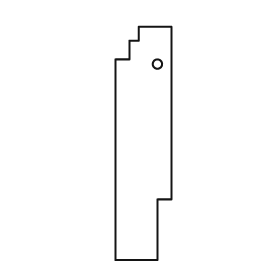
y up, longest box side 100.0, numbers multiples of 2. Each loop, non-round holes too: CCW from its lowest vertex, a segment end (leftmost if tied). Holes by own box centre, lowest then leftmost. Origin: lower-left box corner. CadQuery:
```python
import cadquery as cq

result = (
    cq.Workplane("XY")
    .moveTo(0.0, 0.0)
    .lineTo(18.0, 0.0)
    .lineTo(18.0, 26.0)
    .lineTo(24.0, 26.0)
    .lineTo(24.0, 100.0)
    .lineTo(10.0, 100.0)
    .lineTo(10.0, 94.0)
    .lineTo(6.0, 94.0)
    .lineTo(6.0, 86.0)
    .lineTo(0.0, 86.0)
    .close()
    .moveTo(18.0, 84.0)
    .circle(2.0)
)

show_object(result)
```